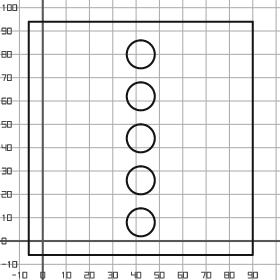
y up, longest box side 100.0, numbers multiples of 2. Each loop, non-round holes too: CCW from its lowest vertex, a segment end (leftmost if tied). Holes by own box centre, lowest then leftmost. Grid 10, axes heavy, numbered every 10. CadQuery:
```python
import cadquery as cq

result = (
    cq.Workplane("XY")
    .moveTo(-6.0, -6.0)
    .lineTo(90.0, -6.0)
    .lineTo(90.0, 94.0)
    .lineTo(-6.0, 94.0)
    .close()
    .moveTo(42.0, 8.0)
    .circle(6.0)
    .moveTo(42.0, 26.0)
    .circle(6.0)
    .moveTo(42.0, 44.0)
    .circle(6.0)
    .moveTo(42.0, 62.0)
    .circle(6.0)
    .moveTo(42.0, 80.0)
    .circle(6.0)
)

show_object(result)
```